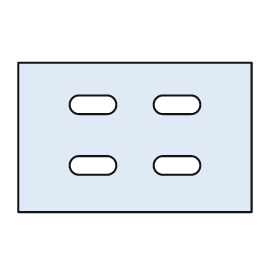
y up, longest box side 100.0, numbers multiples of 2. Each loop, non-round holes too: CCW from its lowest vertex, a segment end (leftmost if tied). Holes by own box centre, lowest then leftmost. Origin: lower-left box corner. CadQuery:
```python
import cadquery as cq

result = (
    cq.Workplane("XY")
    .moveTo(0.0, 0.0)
    .lineTo(100.0, 0.0)
    .lineTo(100.0, 64.0)
    .lineTo(0.0, 64.0)
    .close()
    .moveTo(26.0, 16.0)
    .lineTo(38.0, 16.0)
    .threePointArc((42.0, 20.0), (38.0, 24.0))
    .lineTo(26.0, 24.0)
    .threePointArc((22.0, 20.0), (26.0, 16.0))
    .close()
    .moveTo(62.0, 16.0)
    .lineTo(74.0, 16.0)
    .threePointArc((78.0, 20.0), (74.0, 24.0))
    .lineTo(62.0, 24.0)
    .threePointArc((58.0, 20.0), (62.0, 16.0))
    .close()
    .moveTo(26.0, 42.0)
    .lineTo(38.0, 42.0)
    .threePointArc((42.0, 46.0), (38.0, 50.0))
    .lineTo(26.0, 50.0)
    .threePointArc((22.0, 46.0), (26.0, 42.0))
    .close()
    .moveTo(62.0, 42.0)
    .lineTo(74.0, 42.0)
    .threePointArc((78.0, 46.0), (74.0, 50.0))
    .lineTo(62.0, 50.0)
    .threePointArc((58.0, 46.0), (62.0, 42.0))
    .close()
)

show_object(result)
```